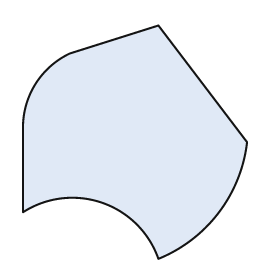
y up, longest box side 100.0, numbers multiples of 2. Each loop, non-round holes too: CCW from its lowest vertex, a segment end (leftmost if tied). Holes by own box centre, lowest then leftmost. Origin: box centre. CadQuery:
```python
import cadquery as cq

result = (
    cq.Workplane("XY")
    .moveTo(10.0, -50.0)
    .threePointArc((36.0, -30.0), (48.0, 0.0))
    .lineTo(10.0, 50.0)
    .lineTo(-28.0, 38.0)
    .threePointArc((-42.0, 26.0), (-48.0, 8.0))
    .lineTo(-48.0, -30.0)
    .threePointArc((-14.0, -26.0), (10.0, -50.0))
    .close()
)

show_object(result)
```